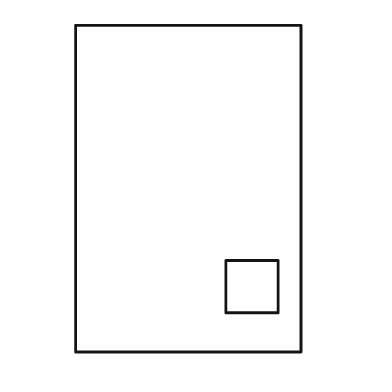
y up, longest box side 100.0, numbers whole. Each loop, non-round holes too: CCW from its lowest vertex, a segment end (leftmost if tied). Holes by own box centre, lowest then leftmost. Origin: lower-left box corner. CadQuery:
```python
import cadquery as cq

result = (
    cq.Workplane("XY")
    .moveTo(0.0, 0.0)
    .lineTo(69.0, 0.0)
    .lineTo(69.0, 100.0)
    .lineTo(0.0, 100.0)
    .close()
    .moveTo(46.0, 12.0)
    .lineTo(62.0, 12.0)
    .lineTo(62.0, 28.0)
    .lineTo(46.0, 28.0)
    .close()
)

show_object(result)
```